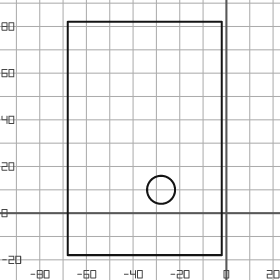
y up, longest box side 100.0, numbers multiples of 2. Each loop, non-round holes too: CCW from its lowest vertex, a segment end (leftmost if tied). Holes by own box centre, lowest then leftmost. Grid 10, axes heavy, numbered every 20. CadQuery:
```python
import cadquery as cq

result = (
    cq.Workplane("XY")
    .moveTo(-68.0, -18.0)
    .lineTo(-2.0, -18.0)
    .lineTo(-2.0, 82.0)
    .lineTo(-68.0, 82.0)
    .close()
    .moveTo(-28.0, 10.0)
    .circle(6.0)
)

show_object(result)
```